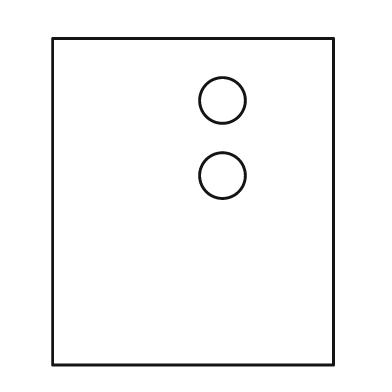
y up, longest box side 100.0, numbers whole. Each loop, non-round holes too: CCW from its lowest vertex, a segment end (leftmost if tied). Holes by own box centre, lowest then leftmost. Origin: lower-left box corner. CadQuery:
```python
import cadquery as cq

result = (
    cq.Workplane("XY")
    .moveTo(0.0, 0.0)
    .lineTo(86.0, 0.0)
    .lineTo(86.0, 100.0)
    .lineTo(0.0, 100.0)
    .close()
    .moveTo(52.0, 58.0)
    .circle(7.0)
    .moveTo(52.0, 81.0)
    .circle(7.0)
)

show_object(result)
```